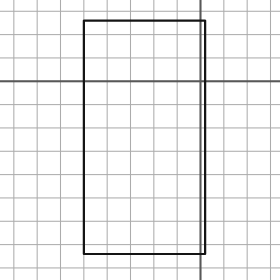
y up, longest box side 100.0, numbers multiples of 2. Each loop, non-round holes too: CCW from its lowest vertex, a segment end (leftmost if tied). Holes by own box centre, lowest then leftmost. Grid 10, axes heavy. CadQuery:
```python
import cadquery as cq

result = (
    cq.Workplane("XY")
    .moveTo(-50.0, -74.0)
    .lineTo(2.0, -74.0)
    .lineTo(2.0, 26.0)
    .lineTo(-50.0, 26.0)
    .close()
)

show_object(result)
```